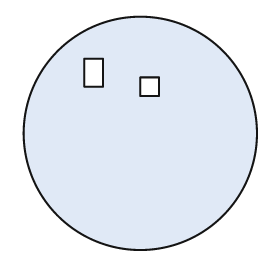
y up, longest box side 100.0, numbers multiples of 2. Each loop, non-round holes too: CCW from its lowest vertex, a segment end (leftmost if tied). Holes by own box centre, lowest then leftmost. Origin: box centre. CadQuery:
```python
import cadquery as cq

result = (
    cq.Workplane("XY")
    .moveTo(0.0, 0.0)
    .circle(50.0)
    .moveTo(0.0, 16.0)
    .lineTo(8.0, 16.0)
    .lineTo(8.0, 24.0)
    .lineTo(0.0, 24.0)
    .close()
    .moveTo(-24.0, 20.0)
    .lineTo(-16.0, 20.0)
    .lineTo(-16.0, 32.0)
    .lineTo(-24.0, 32.0)
    .close()
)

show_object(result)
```